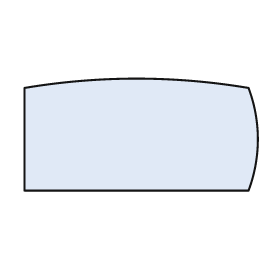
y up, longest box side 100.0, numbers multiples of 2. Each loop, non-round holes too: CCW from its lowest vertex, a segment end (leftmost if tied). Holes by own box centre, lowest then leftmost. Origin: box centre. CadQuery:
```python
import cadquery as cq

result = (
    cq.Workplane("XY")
    .moveTo(-50.0, -24.0)
    .lineTo(46.0, -24.0)
    .threePointArc((50.0, -2.0), (46.0, 20.0))
    .threePointArc((-2.0, 24.0), (-50.0, 20.0))
    .close()
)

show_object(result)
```